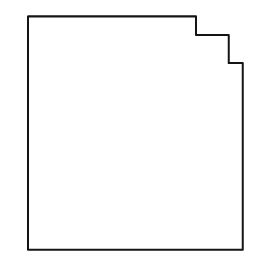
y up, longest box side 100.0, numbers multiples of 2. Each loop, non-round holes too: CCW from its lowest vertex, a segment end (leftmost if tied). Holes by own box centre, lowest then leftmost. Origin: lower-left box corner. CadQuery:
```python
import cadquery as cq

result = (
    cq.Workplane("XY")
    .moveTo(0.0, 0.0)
    .lineTo(92.0, 0.0)
    .lineTo(92.0, 80.0)
    .lineTo(86.0, 80.0)
    .lineTo(86.0, 92.0)
    .lineTo(72.0, 92.0)
    .lineTo(72.0, 100.0)
    .lineTo(0.0, 100.0)
    .close()
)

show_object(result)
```